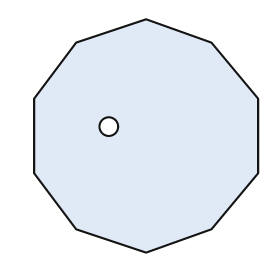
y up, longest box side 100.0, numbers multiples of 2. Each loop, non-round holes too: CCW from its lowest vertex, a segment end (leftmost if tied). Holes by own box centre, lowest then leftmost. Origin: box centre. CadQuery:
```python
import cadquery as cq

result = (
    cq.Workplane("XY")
    .moveTo(0.0, -50.0)
    .lineTo(28.0, -40.0)
    .lineTo(48.0, -16.0)
    .lineTo(48.0, 16.0)
    .lineTo(28.0, 40.0)
    .lineTo(0.0, 50.0)
    .lineTo(-30.0, 40.0)
    .lineTo(-48.0, 16.0)
    .lineTo(-48.0, -16.0)
    .lineTo(-30.0, -40.0)
    .close()
    .moveTo(-16.0, 4.0)
    .circle(4.0)
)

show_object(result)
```